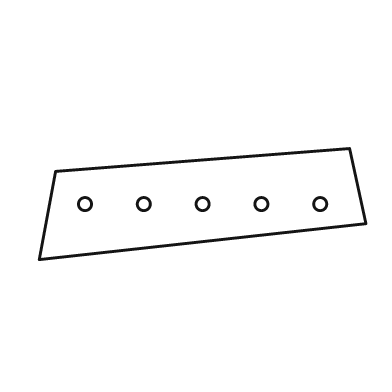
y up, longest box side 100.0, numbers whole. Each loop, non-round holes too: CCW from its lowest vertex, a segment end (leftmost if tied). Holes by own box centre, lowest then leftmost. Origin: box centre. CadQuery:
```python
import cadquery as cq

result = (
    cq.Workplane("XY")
    .moveTo(-50.0, -17.0)
    .lineTo(50.0, -6.0)
    .lineTo(45.0, 17.0)
    .lineTo(-45.0, 10.0)
    .close()
    .moveTo(-36.0, 0.0)
    .circle(2.0)
    .moveTo(-18.0, 0.0)
    .circle(2.0)
    .moveTo(0.0, 0.0)
    .circle(2.0)
    .moveTo(18.0, 0.0)
    .circle(2.0)
    .moveTo(36.0, 0.0)
    .circle(2.0)
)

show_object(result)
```